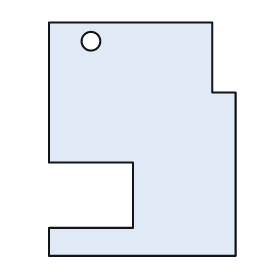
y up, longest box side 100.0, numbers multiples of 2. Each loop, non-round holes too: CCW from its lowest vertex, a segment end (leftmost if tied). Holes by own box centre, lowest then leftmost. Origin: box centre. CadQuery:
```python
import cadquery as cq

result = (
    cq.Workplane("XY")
    .moveTo(-40.0, -50.0)
    .lineTo(40.0, -50.0)
    .lineTo(40.0, 20.0)
    .lineTo(30.0, 20.0)
    .lineTo(30.0, 50.0)
    .lineTo(-40.0, 50.0)
    .lineTo(-40.0, -10.0)
    .lineTo(-4.0, -10.0)
    .lineTo(-4.0, -38.0)
    .lineTo(-40.0, -38.0)
    .close()
    .moveTo(-22.0, 42.0)
    .circle(4.0)
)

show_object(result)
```